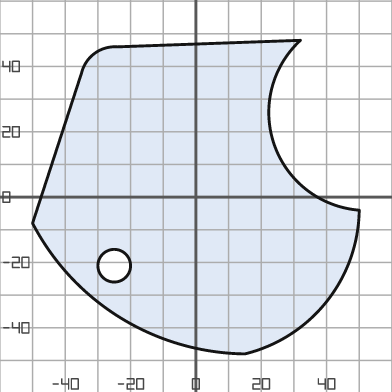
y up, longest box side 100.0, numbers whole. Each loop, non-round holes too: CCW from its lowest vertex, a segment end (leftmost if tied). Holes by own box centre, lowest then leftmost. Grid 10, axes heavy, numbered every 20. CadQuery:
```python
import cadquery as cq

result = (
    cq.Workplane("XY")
    .moveTo(15.0, -48.0)
    .threePointArc((40.0, -32.0), (50.0, -4.0))
    .threePointArc((24.0, 16.0), (32.0, 48.0))
    .lineTo(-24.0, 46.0)
    .threePointArc((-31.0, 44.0), (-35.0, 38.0))
    .lineTo(-50.0, -8.0)
    .threePointArc((-23.0, -37.0), (15.0, -48.0))
    .close()
    .moveTo(-25.0, -21.0)
    .circle(5.0)
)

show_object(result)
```